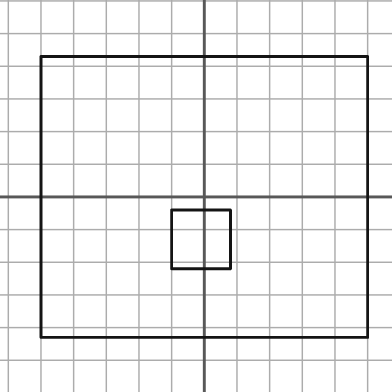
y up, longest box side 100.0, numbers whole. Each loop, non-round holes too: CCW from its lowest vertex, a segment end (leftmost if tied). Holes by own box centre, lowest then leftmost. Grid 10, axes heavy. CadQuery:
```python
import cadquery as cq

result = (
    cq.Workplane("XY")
    .moveTo(-50.0, -43.0)
    .lineTo(50.0, -43.0)
    .lineTo(50.0, 43.0)
    .lineTo(-50.0, 43.0)
    .close()
    .moveTo(-10.0, -22.0)
    .lineTo(8.0, -22.0)
    .lineTo(8.0, -4.0)
    .lineTo(-10.0, -4.0)
    .close()
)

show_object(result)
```